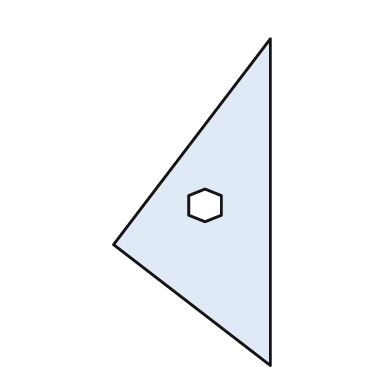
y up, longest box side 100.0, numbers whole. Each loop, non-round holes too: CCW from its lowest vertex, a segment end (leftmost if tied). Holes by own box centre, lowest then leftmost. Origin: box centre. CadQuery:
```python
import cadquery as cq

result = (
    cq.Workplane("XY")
    .moveTo(24.0, -50.0)
    .lineTo(24.0, 50.0)
    .lineTo(-24.0, -13.0)
    .close()
    .moveTo(4.0, -6.0)
    .lineTo(9.0, -4.0)
    .lineTo(9.0, 2.0)
    .lineTo(4.0, 4.0)
    .lineTo(-1.0, 2.0)
    .lineTo(-1.0, -4.0)
    .close()
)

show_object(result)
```